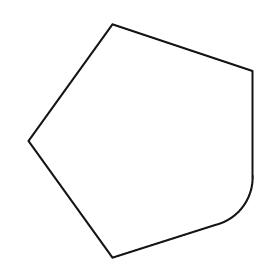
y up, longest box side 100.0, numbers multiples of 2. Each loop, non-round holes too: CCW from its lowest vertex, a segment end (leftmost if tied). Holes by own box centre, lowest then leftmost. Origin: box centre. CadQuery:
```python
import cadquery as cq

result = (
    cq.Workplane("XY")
    .moveTo(-12.0, -50.0)
    .lineTo(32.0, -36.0)
    .threePointArc((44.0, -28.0), (48.0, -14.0))
    .lineTo(48.0, 30.0)
    .lineTo(-12.0, 50.0)
    .lineTo(-48.0, 0.0)
    .close()
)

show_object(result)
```